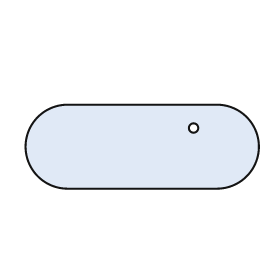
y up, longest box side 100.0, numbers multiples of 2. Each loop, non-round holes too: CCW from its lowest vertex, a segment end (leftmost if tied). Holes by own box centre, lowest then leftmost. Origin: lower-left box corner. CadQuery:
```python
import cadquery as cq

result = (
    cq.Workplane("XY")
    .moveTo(18.0, 0.0)
    .lineTo(82.0, 0.0)
    .threePointArc((100.0, 18.0), (82.0, 36.0))
    .lineTo(18.0, 36.0)
    .threePointArc((0.0, 18.0), (18.0, 0.0))
    .close()
    .moveTo(72.0, 26.0)
    .circle(2.0)
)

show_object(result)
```